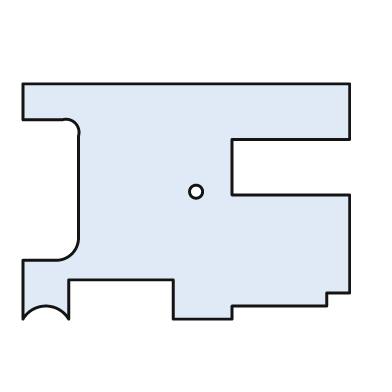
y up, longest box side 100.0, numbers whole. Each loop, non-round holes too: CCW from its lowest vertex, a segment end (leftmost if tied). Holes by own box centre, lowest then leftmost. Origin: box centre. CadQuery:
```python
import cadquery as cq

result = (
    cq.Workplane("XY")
    .moveTo(-50.0, -36.0)
    .threePointArc((-43.0, -32.0), (-36.0, -36.0))
    .lineTo(-36.0, -24.0)
    .lineTo(-4.0, -24.0)
    .lineTo(-4.0, -36.0)
    .lineTo(14.0, -36.0)
    .lineTo(14.0, -32.0)
    .lineTo(43.0, -32.0)
    .lineTo(43.0, -28.0)
    .lineTo(50.0, -28.0)
    .lineTo(50.0, 2.0)
    .lineTo(14.0, 2.0)
    .lineTo(14.0, 19.0)
    .lineTo(50.0, 19.0)
    .lineTo(50.0, 36.0)
    .lineTo(-50.0, 36.0)
    .lineTo(-50.0, 25.0)
    .lineTo(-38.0, 25.0)
    .threePointArc((-34.0, 24.0), (-33.0, 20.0))
    .lineTo(-33.0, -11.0)
    .threePointArc((-35.0, -16.0), (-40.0, -18.0))
    .lineTo(-50.0, -18.0)
    .close()
    .moveTo(3.0, 3.0)
    .circle(2.0)
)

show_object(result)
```